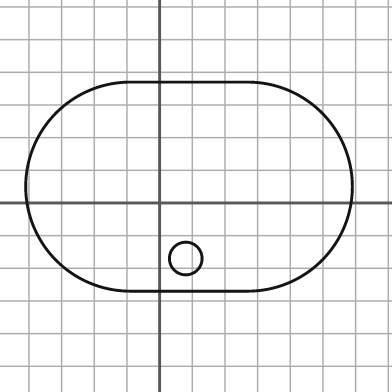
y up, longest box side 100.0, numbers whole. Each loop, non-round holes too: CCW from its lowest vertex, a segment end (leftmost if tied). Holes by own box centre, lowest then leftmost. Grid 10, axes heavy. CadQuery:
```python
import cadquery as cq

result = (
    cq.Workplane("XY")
    .moveTo(-9.0, -27.0)
    .lineTo(27.0, -27.0)
    .threePointArc((59.0, 5.0), (27.0, 37.0))
    .lineTo(-9.0, 37.0)
    .threePointArc((-41.0, 5.0), (-9.0, -27.0))
    .close()
    .moveTo(8.0, -17.0)
    .circle(5.0)
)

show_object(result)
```